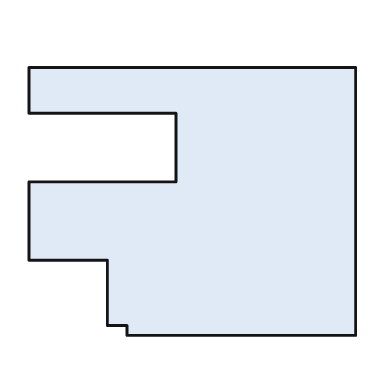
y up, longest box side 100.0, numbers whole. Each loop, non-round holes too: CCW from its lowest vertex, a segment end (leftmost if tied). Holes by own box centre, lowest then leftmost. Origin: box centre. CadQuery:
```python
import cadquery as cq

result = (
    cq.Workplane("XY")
    .moveTo(-20.0, -41.0)
    .lineTo(50.0, -41.0)
    .lineTo(50.0, 41.0)
    .lineTo(-50.0, 41.0)
    .lineTo(-50.0, 27.0)
    .lineTo(-5.0, 27.0)
    .lineTo(-5.0, 6.0)
    .lineTo(-50.0, 6.0)
    .lineTo(-50.0, -18.0)
    .lineTo(-26.0, -18.0)
    .lineTo(-26.0, -38.0)
    .lineTo(-20.0, -38.0)
    .close()
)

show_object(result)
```